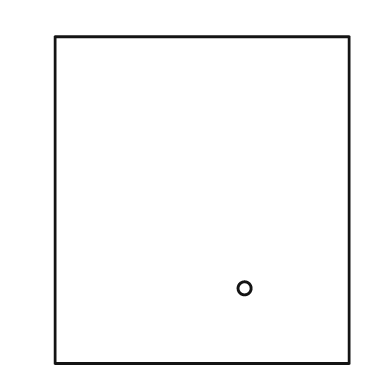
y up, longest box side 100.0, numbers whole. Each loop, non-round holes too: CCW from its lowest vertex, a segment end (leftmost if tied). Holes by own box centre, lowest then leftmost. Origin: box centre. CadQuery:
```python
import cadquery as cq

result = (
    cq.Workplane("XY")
    .moveTo(-45.0, -50.0)
    .lineTo(45.0, -50.0)
    .lineTo(45.0, 50.0)
    .lineTo(-45.0, 50.0)
    .close()
    .moveTo(13.0, -27.0)
    .circle(2.0)
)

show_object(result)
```